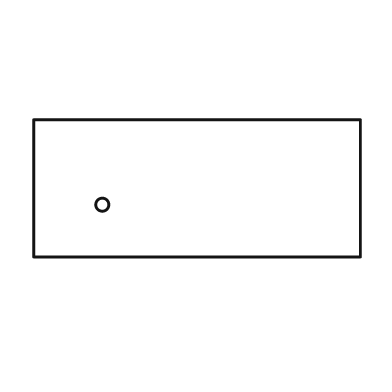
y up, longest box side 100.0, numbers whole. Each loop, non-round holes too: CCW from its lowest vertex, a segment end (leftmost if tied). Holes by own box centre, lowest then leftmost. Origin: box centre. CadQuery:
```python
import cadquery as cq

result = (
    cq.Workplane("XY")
    .moveTo(-50.0, -21.0)
    .lineTo(50.0, -21.0)
    .lineTo(50.0, 21.0)
    .lineTo(-50.0, 21.0)
    .close()
    .moveTo(-29.0, -5.0)
    .circle(2.0)
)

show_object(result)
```